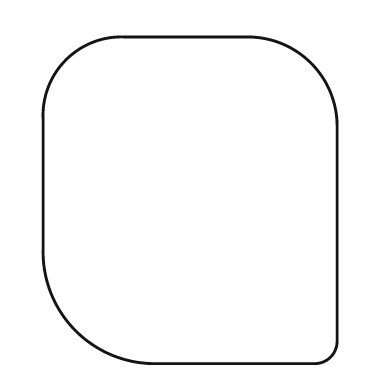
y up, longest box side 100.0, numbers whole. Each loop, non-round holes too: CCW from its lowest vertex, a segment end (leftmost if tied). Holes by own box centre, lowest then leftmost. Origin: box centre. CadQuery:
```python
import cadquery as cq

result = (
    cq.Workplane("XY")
    .moveTo(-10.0, -50.0)
    .lineTo(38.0, -50.0)
    .threePointArc((43.0, -48.0), (45.0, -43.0))
    .lineTo(45.0, 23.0)
    .threePointArc((37.0, 42.0), (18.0, 50.0))
    .lineTo(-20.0, 50.0)
    .threePointArc((-38.0, 43.0), (-45.0, 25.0))
    .lineTo(-45.0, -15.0)
    .threePointArc((-35.0, -40.0), (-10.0, -50.0))
    .close()
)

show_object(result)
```